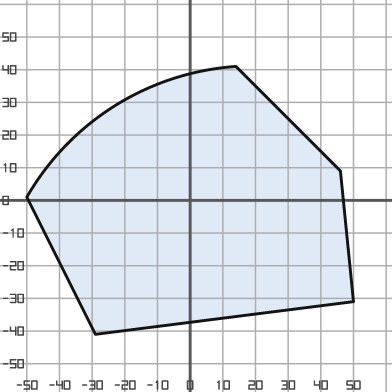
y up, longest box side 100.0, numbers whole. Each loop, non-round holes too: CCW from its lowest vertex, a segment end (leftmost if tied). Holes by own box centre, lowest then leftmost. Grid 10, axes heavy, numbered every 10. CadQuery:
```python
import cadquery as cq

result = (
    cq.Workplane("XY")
    .moveTo(-29.0, -41.0)
    .lineTo(50.0, -31.0)
    .lineTo(46.0, 9.0)
    .lineTo(14.0, 41.0)
    .threePointArc((-23.0, 29.0), (-50.0, 1.0))
    .close()
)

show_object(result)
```